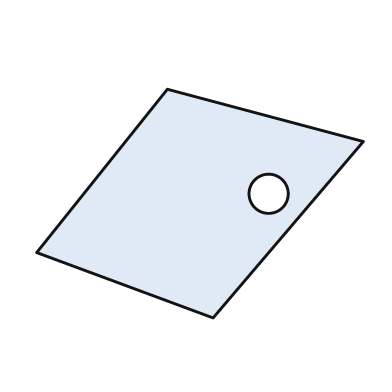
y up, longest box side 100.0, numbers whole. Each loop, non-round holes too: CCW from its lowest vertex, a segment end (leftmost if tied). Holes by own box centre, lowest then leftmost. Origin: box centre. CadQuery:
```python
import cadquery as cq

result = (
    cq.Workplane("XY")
    .moveTo(4.0, -35.0)
    .lineTo(50.0, 19.0)
    .lineTo(-10.0, 35.0)
    .lineTo(-50.0, -15.0)
    .close()
    .moveTo(21.0, 3.0)
    .circle(6.0)
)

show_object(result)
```